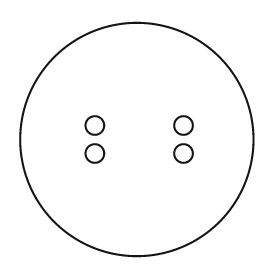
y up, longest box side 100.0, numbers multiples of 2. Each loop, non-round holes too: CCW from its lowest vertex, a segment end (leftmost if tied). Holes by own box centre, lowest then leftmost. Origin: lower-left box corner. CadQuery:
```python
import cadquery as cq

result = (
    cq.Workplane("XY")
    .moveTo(50.0, 50.0)
    .circle(50.0)
    .moveTo(32.0, 44.0)
    .circle(4.0)
    .moveTo(70.0, 44.0)
    .circle(4.0)
    .moveTo(32.0, 56.0)
    .circle(4.0)
    .moveTo(70.0, 56.0)
    .circle(4.0)
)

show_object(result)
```